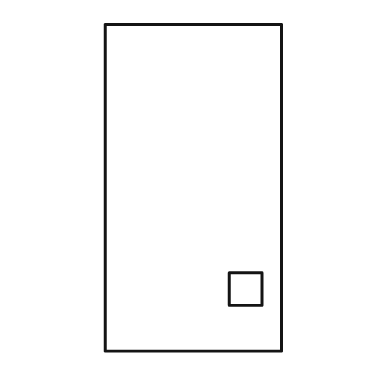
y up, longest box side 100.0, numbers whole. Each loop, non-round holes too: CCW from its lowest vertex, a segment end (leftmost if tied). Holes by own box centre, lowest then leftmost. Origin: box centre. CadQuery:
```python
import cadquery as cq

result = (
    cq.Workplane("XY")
    .moveTo(-27.0, -50.0)
    .lineTo(27.0, -50.0)
    .lineTo(27.0, 50.0)
    .lineTo(-27.0, 50.0)
    .close()
    .moveTo(11.0, -36.0)
    .lineTo(21.0, -36.0)
    .lineTo(21.0, -26.0)
    .lineTo(11.0, -26.0)
    .close()
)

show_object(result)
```